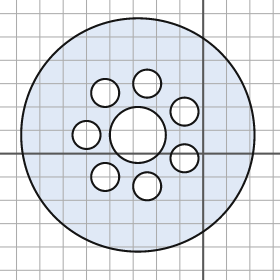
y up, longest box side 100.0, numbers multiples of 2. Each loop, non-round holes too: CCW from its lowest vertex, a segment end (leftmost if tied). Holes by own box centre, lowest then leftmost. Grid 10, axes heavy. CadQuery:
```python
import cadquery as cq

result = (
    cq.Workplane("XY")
    .moveTo(-28.0, 8.0)
    .circle(50.0)
    .moveTo(-24.0, -14.0)
    .circle(6.0)
    .moveTo(-42.0, -10.0)
    .circle(6.0)
    .moveTo(-8.0, -2.0)
    .circle(6.0)
    .moveTo(-50.0, 8.0)
    .circle(6.0)
    .moveTo(-28.0, 8.0)
    .circle(12.0)
    .moveTo(-8.0, 18.0)
    .circle(6.0)
    .moveTo(-42.0, 26.0)
    .circle(6.0)
    .moveTo(-24.0, 30.0)
    .circle(6.0)
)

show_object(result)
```